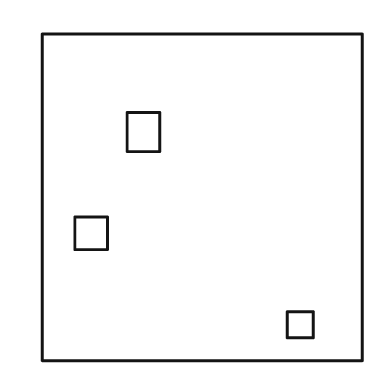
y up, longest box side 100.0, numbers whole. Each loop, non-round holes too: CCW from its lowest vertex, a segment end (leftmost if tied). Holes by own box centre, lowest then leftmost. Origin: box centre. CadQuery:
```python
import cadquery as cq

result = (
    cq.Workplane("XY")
    .moveTo(-49.0, -50.0)
    .lineTo(49.0, -50.0)
    .lineTo(49.0, 50.0)
    .lineTo(-49.0, 50.0)
    .close()
    .moveTo(26.0, -43.0)
    .lineTo(34.0, -43.0)
    .lineTo(34.0, -35.0)
    .lineTo(26.0, -35.0)
    .close()
    .moveTo(-39.0, -16.0)
    .lineTo(-29.0, -16.0)
    .lineTo(-29.0, -6.0)
    .lineTo(-39.0, -6.0)
    .close()
    .moveTo(-23.0, 14.0)
    .lineTo(-13.0, 14.0)
    .lineTo(-13.0, 26.0)
    .lineTo(-23.0, 26.0)
    .close()
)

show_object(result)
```